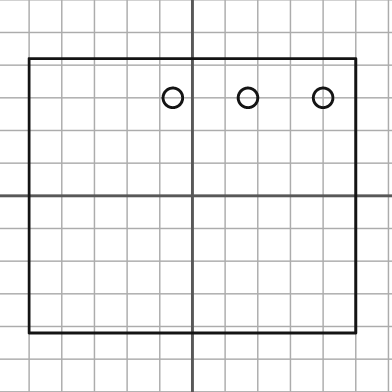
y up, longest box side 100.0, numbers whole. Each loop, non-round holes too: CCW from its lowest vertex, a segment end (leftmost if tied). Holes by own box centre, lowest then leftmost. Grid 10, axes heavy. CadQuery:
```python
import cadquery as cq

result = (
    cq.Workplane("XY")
    .moveTo(-50.0, -42.0)
    .lineTo(50.0, -42.0)
    .lineTo(50.0, 42.0)
    .lineTo(-50.0, 42.0)
    .close()
    .moveTo(-6.0, 30.0)
    .circle(3.0)
    .moveTo(17.0, 30.0)
    .circle(3.0)
    .moveTo(40.0, 30.0)
    .circle(3.0)
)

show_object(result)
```